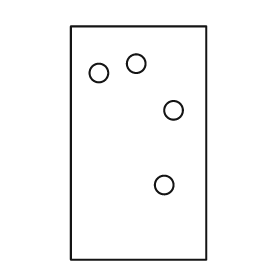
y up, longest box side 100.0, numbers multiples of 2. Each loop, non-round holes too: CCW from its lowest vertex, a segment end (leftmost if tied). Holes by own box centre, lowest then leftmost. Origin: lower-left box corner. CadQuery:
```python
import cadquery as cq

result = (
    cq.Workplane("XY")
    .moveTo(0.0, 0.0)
    .lineTo(58.0, 0.0)
    .lineTo(58.0, 100.0)
    .lineTo(0.0, 100.0)
    .close()
    .moveTo(40.0, 32.0)
    .circle(4.0)
    .moveTo(44.0, 64.0)
    .circle(4.0)
    .moveTo(12.0, 80.0)
    .circle(4.0)
    .moveTo(28.0, 84.0)
    .circle(4.0)
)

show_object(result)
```